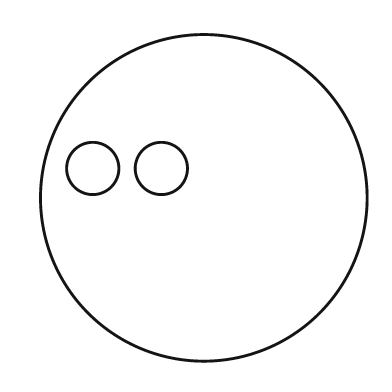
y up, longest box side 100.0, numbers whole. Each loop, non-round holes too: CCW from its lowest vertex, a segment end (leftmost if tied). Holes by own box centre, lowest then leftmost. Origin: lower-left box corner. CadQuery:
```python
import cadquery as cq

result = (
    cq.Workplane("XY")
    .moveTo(50.0, 50.0)
    .circle(50.0)
    .moveTo(16.0, 59.0)
    .circle(8.0)
    .moveTo(37.0, 59.0)
    .circle(8.0)
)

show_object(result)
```